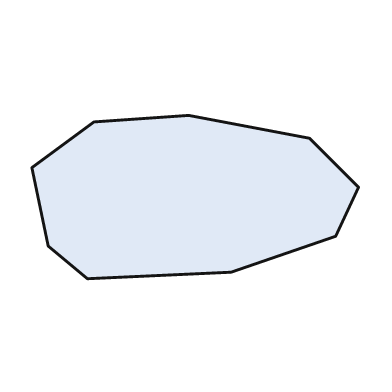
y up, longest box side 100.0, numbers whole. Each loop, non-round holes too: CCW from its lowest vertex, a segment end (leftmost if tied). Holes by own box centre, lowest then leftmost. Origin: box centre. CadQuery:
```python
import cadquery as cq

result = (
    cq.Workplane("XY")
    .moveTo(-33.0, -25.0)
    .lineTo(11.0, -23.0)
    .lineTo(43.0, -12.0)
    .lineTo(50.0, 3.0)
    .lineTo(35.0, 18.0)
    .lineTo(-2.0, 25.0)
    .lineTo(-31.0, 23.0)
    .lineTo(-50.0, 9.0)
    .lineTo(-45.0, -15.0)
    .close()
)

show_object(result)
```